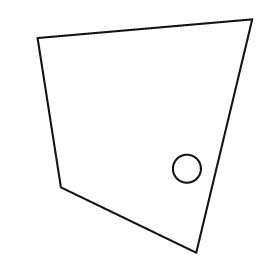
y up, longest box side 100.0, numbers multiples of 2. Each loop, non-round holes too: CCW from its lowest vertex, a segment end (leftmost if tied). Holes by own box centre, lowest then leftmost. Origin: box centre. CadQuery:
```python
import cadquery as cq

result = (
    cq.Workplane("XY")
    .moveTo(22.0, -50.0)
    .lineTo(46.0, 50.0)
    .lineTo(-46.0, 42.0)
    .lineTo(-36.0, -22.0)
    .close()
    .moveTo(18.0, -14.0)
    .circle(6.0)
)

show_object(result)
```